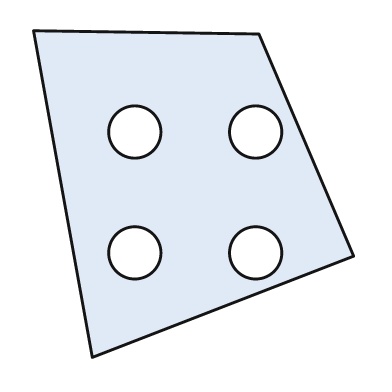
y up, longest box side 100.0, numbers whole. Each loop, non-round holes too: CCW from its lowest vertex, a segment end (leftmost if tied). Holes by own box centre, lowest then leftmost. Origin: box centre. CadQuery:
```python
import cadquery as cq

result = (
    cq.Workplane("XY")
    .moveTo(-31.0, -50.0)
    .lineTo(49.0, -19.0)
    .lineTo(20.0, 49.0)
    .lineTo(-49.0, 50.0)
    .close()
    .moveTo(-18.0, -18.0)
    .circle(8.0)
    .moveTo(19.0, -18.0)
    .circle(8.0)
    .moveTo(-18.0, 19.0)
    .circle(8.0)
    .moveTo(19.0, 19.0)
    .circle(8.0)
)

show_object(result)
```